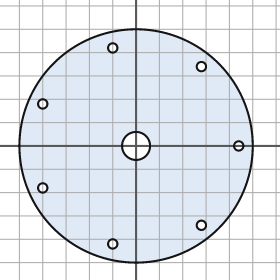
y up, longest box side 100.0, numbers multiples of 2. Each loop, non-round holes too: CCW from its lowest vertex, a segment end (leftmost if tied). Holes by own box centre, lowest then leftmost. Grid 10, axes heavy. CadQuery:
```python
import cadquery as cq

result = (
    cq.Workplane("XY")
    .moveTo(0.0, 0.0)
    .circle(50.0)
    .moveTo(-10.0, -42.0)
    .circle(2.0)
    .moveTo(28.0, -34.0)
    .circle(2.0)
    .moveTo(-40.0, -18.0)
    .circle(2.0)
    .moveTo(0.0, 0.0)
    .circle(6.0)
    .moveTo(44.0, 0.0)
    .circle(2.0)
    .moveTo(-40.0, 18.0)
    .circle(2.0)
    .moveTo(28.0, 34.0)
    .circle(2.0)
    .moveTo(-10.0, 42.0)
    .circle(2.0)
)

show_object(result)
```